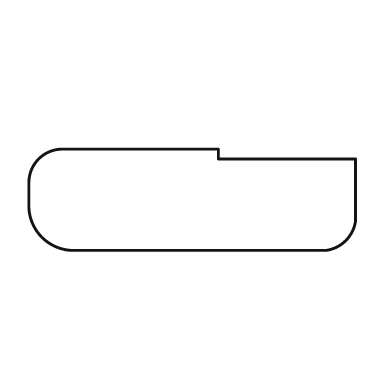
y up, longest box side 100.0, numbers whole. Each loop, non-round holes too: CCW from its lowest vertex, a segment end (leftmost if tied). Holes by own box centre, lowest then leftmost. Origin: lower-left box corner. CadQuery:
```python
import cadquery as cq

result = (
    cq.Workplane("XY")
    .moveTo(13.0, 0.0)
    .lineTo(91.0, 0.0)
    .threePointArc((97.0, 3.0), (100.0, 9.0))
    .lineTo(100.0, 28.0)
    .lineTo(58.0, 28.0)
    .lineTo(58.0, 31.0)
    .lineTo(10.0, 31.0)
    .threePointArc((3.0, 28.0), (0.0, 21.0))
    .lineTo(0.0, 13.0)
    .threePointArc((4.0, 4.0), (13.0, 0.0))
    .close()
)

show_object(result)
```